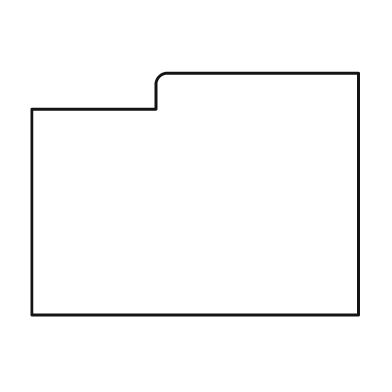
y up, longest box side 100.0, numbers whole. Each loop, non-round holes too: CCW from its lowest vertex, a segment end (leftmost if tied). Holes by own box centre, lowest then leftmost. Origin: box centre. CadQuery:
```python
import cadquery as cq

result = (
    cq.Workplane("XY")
    .moveTo(-50.0, -37.0)
    .lineTo(50.0, -37.0)
    .lineTo(50.0, 37.0)
    .lineTo(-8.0, 37.0)
    .threePointArc((-11.0, 36.0), (-12.0, 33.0))
    .lineTo(-12.0, 26.0)
    .lineTo(-50.0, 26.0)
    .close()
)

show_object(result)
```